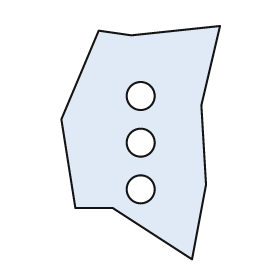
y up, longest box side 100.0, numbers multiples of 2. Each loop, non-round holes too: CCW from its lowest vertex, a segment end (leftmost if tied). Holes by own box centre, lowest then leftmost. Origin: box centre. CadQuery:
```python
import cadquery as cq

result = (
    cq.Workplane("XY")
    .moveTo(22.0, -50.0)
    .lineTo(28.0, -18.0)
    .lineTo(26.0, 16.0)
    .lineTo(34.0, 50.0)
    .lineTo(-4.0, 46.0)
    .lineTo(-18.0, 48.0)
    .lineTo(-34.0, 10.0)
    .lineTo(-28.0, -28.0)
    .lineTo(-12.0, -28.0)
    .close()
    .moveTo(0.0, -20.0)
    .circle(6.0)
    .moveTo(0.0, 0.0)
    .circle(6.0)
    .moveTo(0.0, 20.0)
    .circle(6.0)
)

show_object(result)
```